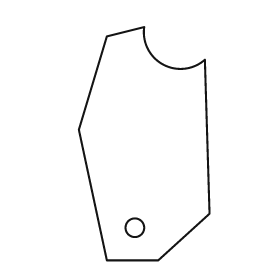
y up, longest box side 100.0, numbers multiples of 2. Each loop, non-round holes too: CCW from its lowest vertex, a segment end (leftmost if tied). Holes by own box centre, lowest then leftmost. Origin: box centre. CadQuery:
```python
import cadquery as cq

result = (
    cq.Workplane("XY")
    .moveTo(-16.0, -50.0)
    .lineTo(6.0, -50.0)
    .lineTo(28.0, -30.0)
    .lineTo(26.0, 36.0)
    .threePointArc((8.0, 34.0), (0.0, 50.0))
    .lineTo(-16.0, 46.0)
    .lineTo(-28.0, 6.0)
    .close()
    .moveTo(-4.0, -36.0)
    .circle(4.0)
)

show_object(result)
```